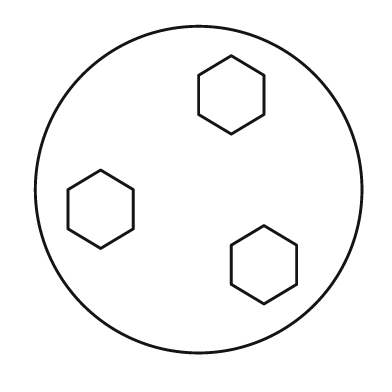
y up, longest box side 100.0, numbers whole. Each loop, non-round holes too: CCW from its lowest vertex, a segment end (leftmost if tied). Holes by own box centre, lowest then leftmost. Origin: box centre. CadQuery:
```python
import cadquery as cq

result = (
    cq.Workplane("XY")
    .moveTo(0.0, 0.0)
    .circle(50.0)
    .moveTo(20.0, -35.0)
    .lineTo(30.0, -29.0)
    .lineTo(30.0, -17.0)
    .lineTo(20.0, -11.0)
    .lineTo(10.0, -17.0)
    .lineTo(10.0, -29.0)
    .close()
    .moveTo(-30.0, -18.0)
    .lineTo(-20.0, -12.0)
    .lineTo(-20.0, 0.0)
    .lineTo(-30.0, 6.0)
    .lineTo(-40.0, 0.0)
    .lineTo(-40.0, -12.0)
    .close()
    .moveTo(10.0, 17.0)
    .lineTo(20.0, 23.0)
    .lineTo(20.0, 35.0)
    .lineTo(10.0, 41.0)
    .lineTo(0.0, 35.0)
    .lineTo(0.0, 23.0)
    .close()
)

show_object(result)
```